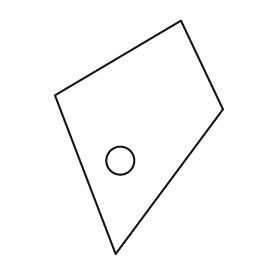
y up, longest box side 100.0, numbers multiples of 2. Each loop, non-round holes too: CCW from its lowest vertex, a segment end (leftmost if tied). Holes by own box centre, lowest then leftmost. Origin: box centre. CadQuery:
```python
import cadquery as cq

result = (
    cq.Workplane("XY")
    .moveTo(-10.0, -50.0)
    .lineTo(36.0, 12.0)
    .lineTo(18.0, 50.0)
    .lineTo(-36.0, 18.0)
    .close()
    .moveTo(-8.0, -10.0)
    .circle(6.0)
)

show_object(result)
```